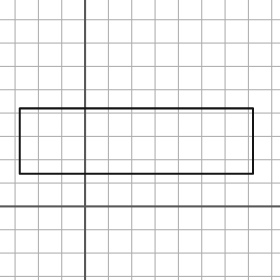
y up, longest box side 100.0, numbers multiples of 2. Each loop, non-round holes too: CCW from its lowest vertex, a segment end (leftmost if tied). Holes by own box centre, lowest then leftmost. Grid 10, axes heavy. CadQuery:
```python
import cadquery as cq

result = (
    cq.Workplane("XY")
    .moveTo(-28.0, 14.0)
    .lineTo(72.0, 14.0)
    .lineTo(72.0, 42.0)
    .lineTo(-28.0, 42.0)
    .close()
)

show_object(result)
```